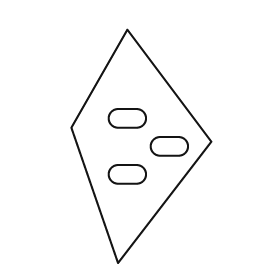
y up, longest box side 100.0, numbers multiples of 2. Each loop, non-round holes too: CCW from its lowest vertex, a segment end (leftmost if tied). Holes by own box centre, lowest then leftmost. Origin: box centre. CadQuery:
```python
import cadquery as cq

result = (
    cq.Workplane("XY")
    .moveTo(-10.0, -50.0)
    .lineTo(30.0, 2.0)
    .lineTo(-6.0, 50.0)
    .lineTo(-30.0, 8.0)
    .close()
    .moveTo(-10.0, -16.0)
    .lineTo(-2.0, -16.0)
    .threePointArc((2.0, -12.0), (-2.0, -8.0))
    .lineTo(-10.0, -8.0)
    .threePointArc((-14.0, -12.0), (-10.0, -16.0))
    .close()
    .moveTo(8.0, -4.0)
    .lineTo(16.0, -4.0)
    .threePointArc((20.0, 0.0), (16.0, 4.0))
    .lineTo(8.0, 4.0)
    .threePointArc((4.0, 0.0), (8.0, -4.0))
    .close()
    .moveTo(-10.0, 8.0)
    .lineTo(-2.0, 8.0)
    .threePointArc((2.0, 12.0), (-2.0, 16.0))
    .lineTo(-10.0, 16.0)
    .threePointArc((-14.0, 12.0), (-10.0, 8.0))
    .close()
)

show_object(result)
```